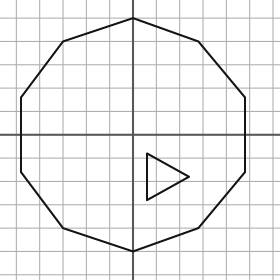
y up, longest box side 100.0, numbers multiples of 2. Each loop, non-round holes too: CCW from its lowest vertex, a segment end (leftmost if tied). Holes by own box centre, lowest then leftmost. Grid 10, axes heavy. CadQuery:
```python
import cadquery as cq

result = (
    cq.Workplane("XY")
    .moveTo(0.0, -50.0)
    .lineTo(28.0, -40.0)
    .lineTo(48.0, -16.0)
    .lineTo(48.0, 16.0)
    .lineTo(28.0, 40.0)
    .lineTo(0.0, 50.0)
    .lineTo(-30.0, 40.0)
    .lineTo(-48.0, 16.0)
    .lineTo(-48.0, -16.0)
    .lineTo(-30.0, -40.0)
    .close()
    .moveTo(6.0, -28.0)
    .lineTo(24.0, -18.0)
    .lineTo(6.0, -8.0)
    .close()
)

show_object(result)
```